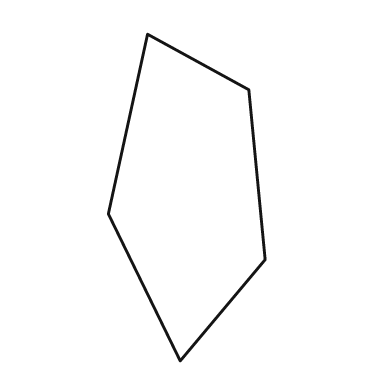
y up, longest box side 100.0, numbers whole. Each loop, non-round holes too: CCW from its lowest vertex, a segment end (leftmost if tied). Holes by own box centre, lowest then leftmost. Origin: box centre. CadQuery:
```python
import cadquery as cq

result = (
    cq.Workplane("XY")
    .moveTo(-2.0, -50.0)
    .lineTo(24.0, -19.0)
    .lineTo(19.0, 33.0)
    .lineTo(-12.0, 50.0)
    .lineTo(-24.0, -5.0)
    .close()
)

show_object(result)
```